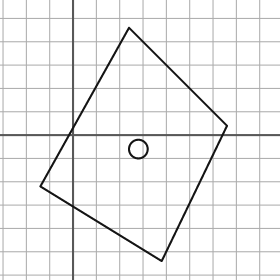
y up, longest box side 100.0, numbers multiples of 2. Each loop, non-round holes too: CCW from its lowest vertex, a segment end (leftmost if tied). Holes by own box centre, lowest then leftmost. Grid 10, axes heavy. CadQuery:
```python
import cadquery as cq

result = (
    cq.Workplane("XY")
    .moveTo(38.0, -54.0)
    .lineTo(66.0, 4.0)
    .lineTo(24.0, 46.0)
    .lineTo(-14.0, -22.0)
    .close()
    .moveTo(28.0, -6.0)
    .circle(4.0)
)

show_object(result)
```